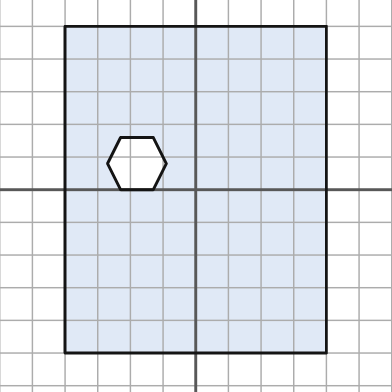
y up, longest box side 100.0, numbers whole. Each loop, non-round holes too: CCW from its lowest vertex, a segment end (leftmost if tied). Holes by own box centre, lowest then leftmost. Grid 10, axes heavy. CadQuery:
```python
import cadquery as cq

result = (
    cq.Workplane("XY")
    .moveTo(-40.0, -50.0)
    .lineTo(40.0, -50.0)
    .lineTo(40.0, 50.0)
    .lineTo(-40.0, 50.0)
    .close()
    .moveTo(-23.0, 0.0)
    .lineTo(-13.0, 0.0)
    .lineTo(-9.0, 8.0)
    .lineTo(-13.0, 16.0)
    .lineTo(-23.0, 16.0)
    .lineTo(-27.0, 8.0)
    .close()
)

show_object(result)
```